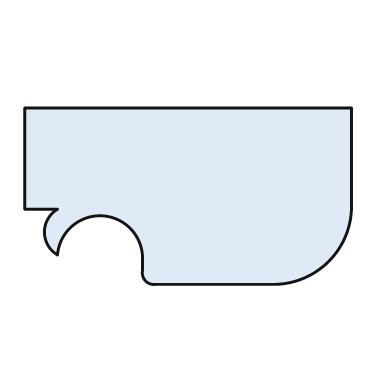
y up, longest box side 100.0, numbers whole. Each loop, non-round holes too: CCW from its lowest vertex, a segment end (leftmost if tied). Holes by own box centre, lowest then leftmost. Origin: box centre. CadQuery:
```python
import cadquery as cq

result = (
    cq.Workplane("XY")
    .moveTo(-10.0, -27.0)
    .lineTo(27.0, -27.0)
    .threePointArc((43.0, -20.0), (50.0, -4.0))
    .lineTo(50.0, 27.0)
    .lineTo(-50.0, 27.0)
    .lineTo(-50.0, -4.0)
    .lineTo(-40.0, -4.0)
    .threePointArc((-44.0, -11.0), (-40.0, -18.0))
    .threePointArc((-27.0, -6.0), (-14.0, -18.0))
    .lineTo(-14.0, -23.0)
    .threePointArc((-13.0, -26.0), (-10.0, -27.0))
    .close()
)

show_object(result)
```